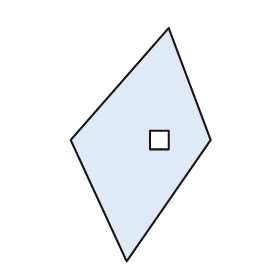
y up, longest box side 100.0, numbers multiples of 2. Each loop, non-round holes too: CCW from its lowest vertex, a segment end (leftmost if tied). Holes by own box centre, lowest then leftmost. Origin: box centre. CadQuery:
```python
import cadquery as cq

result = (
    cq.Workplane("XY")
    .moveTo(-6.0, -50.0)
    .lineTo(30.0, 2.0)
    .lineTo(12.0, 50.0)
    .lineTo(-30.0, 2.0)
    .close()
    .moveTo(4.0, -2.0)
    .lineTo(12.0, -2.0)
    .lineTo(12.0, 6.0)
    .lineTo(4.0, 6.0)
    .close()
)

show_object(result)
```